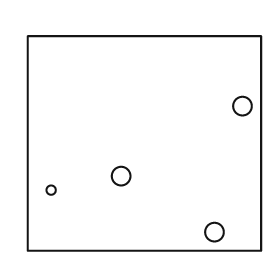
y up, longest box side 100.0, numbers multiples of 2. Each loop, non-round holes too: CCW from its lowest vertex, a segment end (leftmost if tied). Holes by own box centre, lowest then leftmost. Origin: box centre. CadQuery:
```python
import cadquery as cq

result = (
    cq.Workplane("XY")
    .moveTo(-50.0, -46.0)
    .lineTo(50.0, -46.0)
    .lineTo(50.0, 46.0)
    .lineTo(-50.0, 46.0)
    .close()
    .moveTo(30.0, -38.0)
    .circle(4.0)
    .moveTo(-40.0, -20.0)
    .circle(2.0)
    .moveTo(-10.0, -14.0)
    .circle(4.0)
    .moveTo(42.0, 16.0)
    .circle(4.0)
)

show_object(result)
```